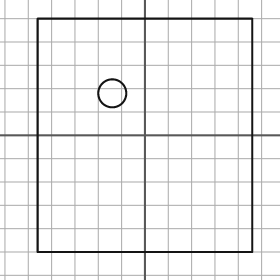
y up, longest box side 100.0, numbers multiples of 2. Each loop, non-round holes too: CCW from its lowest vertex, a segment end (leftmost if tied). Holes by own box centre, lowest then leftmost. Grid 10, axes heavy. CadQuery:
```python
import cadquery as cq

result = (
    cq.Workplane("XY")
    .moveTo(-46.0, -50.0)
    .lineTo(46.0, -50.0)
    .lineTo(46.0, 50.0)
    .lineTo(-46.0, 50.0)
    .close()
    .moveTo(-14.0, 18.0)
    .circle(6.0)
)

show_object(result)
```